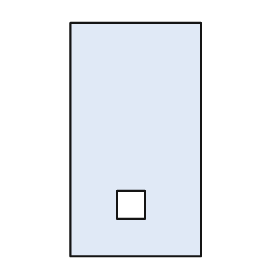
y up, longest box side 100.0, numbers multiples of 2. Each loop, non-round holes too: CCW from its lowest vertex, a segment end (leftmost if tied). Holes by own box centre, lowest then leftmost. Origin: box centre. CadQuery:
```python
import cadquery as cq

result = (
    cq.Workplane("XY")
    .moveTo(-28.0, -50.0)
    .lineTo(28.0, -50.0)
    .lineTo(28.0, 50.0)
    .lineTo(-28.0, 50.0)
    .close()
    .moveTo(-8.0, -34.0)
    .lineTo(4.0, -34.0)
    .lineTo(4.0, -22.0)
    .lineTo(-8.0, -22.0)
    .close()
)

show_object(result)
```